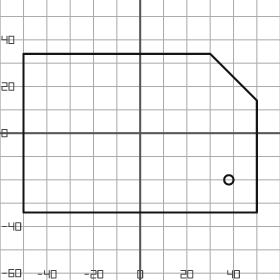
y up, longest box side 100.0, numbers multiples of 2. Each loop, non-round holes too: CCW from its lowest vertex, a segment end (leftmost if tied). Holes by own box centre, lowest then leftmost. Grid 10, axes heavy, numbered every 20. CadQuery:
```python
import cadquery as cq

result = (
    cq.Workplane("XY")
    .moveTo(-50.0, -34.0)
    .lineTo(50.0, -34.0)
    .lineTo(50.0, 14.0)
    .lineTo(30.0, 34.0)
    .lineTo(-50.0, 34.0)
    .close()
    .moveTo(38.0, -20.0)
    .circle(2.0)
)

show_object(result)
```